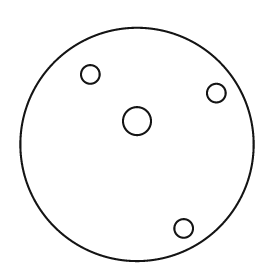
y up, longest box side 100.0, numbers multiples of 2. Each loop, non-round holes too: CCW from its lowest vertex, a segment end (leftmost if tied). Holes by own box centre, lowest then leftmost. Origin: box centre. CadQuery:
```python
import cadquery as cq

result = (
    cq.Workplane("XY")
    .moveTo(0.0, 0.0)
    .circle(50.0)
    .moveTo(20.0, -36.0)
    .circle(4.0)
    .moveTo(0.0, 10.0)
    .circle(6.0)
    .moveTo(34.0, 22.0)
    .circle(4.0)
    .moveTo(-20.0, 30.0)
    .circle(4.0)
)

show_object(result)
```